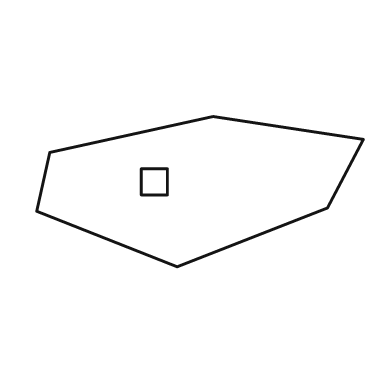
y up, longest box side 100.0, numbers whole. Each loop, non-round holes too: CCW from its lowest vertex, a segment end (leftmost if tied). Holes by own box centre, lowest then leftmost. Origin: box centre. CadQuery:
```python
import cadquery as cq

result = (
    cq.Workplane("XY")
    .moveTo(-7.0, -23.0)
    .lineTo(39.0, -5.0)
    .lineTo(50.0, 16.0)
    .lineTo(4.0, 23.0)
    .lineTo(-46.0, 12.0)
    .lineTo(-50.0, -6.0)
    .close()
    .moveTo(-18.0, -1.0)
    .lineTo(-10.0, -1.0)
    .lineTo(-10.0, 7.0)
    .lineTo(-18.0, 7.0)
    .close()
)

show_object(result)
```